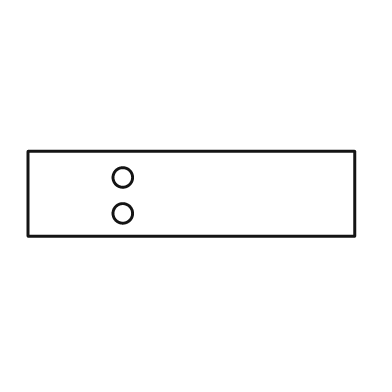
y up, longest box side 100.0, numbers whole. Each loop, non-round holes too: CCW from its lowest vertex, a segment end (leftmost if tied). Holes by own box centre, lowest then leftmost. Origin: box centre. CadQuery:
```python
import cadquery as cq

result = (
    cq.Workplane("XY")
    .moveTo(-50.0, -13.0)
    .lineTo(50.0, -13.0)
    .lineTo(50.0, 13.0)
    .lineTo(-50.0, 13.0)
    .close()
    .moveTo(-21.0, -6.0)
    .circle(3.0)
    .moveTo(-21.0, 5.0)
    .circle(3.0)
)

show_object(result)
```